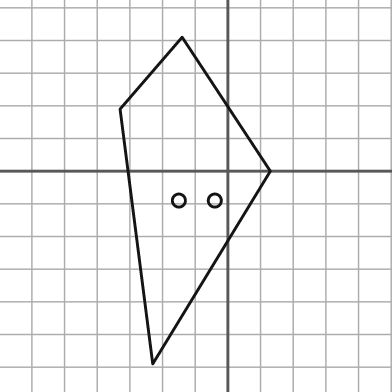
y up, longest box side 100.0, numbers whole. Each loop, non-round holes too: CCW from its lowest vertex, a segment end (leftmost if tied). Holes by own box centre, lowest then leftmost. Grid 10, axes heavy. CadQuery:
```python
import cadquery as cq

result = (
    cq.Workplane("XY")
    .moveTo(-23.0, -59.0)
    .lineTo(13.0, 0.0)
    .lineTo(-14.0, 41.0)
    .lineTo(-33.0, 19.0)
    .close()
    .moveTo(-15.0, -9.0)
    .circle(2.0)
    .moveTo(-4.0, -9.0)
    .circle(2.0)
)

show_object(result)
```